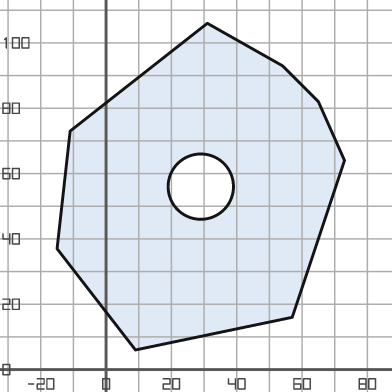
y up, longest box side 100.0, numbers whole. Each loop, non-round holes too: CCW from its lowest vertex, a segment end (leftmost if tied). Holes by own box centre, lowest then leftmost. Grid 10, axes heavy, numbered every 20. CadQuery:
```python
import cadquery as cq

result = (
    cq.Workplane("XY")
    .moveTo(9.0, 6.0)
    .lineTo(57.0, 16.0)
    .lineTo(73.0, 64.0)
    .lineTo(65.0, 82.0)
    .lineTo(54.0, 93.0)
    .lineTo(31.0, 106.0)
    .lineTo(-11.0, 73.0)
    .lineTo(-15.0, 37.0)
    .close()
    .moveTo(29.0, 56.0)
    .circle(10.0)
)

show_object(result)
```